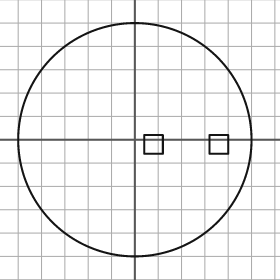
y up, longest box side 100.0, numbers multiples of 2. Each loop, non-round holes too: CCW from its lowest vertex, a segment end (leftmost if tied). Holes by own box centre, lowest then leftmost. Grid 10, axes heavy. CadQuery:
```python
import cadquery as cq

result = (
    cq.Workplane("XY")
    .moveTo(0.0, 0.0)
    .circle(50.0)
    .moveTo(4.0, -6.0)
    .lineTo(12.0, -6.0)
    .lineTo(12.0, 2.0)
    .lineTo(4.0, 2.0)
    .close()
    .moveTo(32.0, -6.0)
    .lineTo(40.0, -6.0)
    .lineTo(40.0, 2.0)
    .lineTo(32.0, 2.0)
    .close()
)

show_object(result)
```